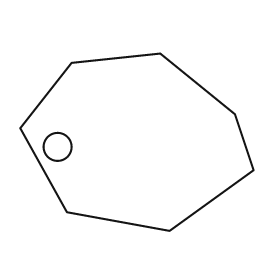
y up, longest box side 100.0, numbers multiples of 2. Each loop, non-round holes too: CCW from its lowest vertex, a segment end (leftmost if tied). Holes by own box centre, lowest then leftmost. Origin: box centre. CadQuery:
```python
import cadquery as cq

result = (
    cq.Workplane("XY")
    .moveTo(14.0, -38.0)
    .lineTo(50.0, -12.0)
    .lineTo(42.0, 12.0)
    .lineTo(10.0, 38.0)
    .lineTo(-28.0, 34.0)
    .lineTo(-50.0, 6.0)
    .lineTo(-30.0, -30.0)
    .close()
    .moveTo(-34.0, -2.0)
    .circle(6.0)
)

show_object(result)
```